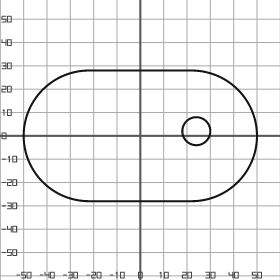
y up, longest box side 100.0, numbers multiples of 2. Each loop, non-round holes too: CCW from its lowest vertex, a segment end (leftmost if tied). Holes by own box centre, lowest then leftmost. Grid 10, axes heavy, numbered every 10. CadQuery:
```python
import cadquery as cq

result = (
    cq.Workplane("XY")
    .moveTo(-22.0, -28.0)
    .lineTo(22.0, -28.0)
    .threePointArc((50.0, 0.0), (22.0, 28.0))
    .lineTo(-22.0, 28.0)
    .threePointArc((-50.0, 0.0), (-22.0, -28.0))
    .close()
    .moveTo(24.0, 2.0)
    .circle(6.0)
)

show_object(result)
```